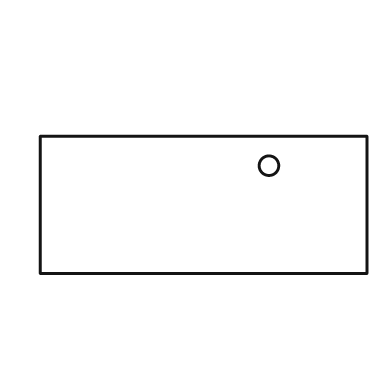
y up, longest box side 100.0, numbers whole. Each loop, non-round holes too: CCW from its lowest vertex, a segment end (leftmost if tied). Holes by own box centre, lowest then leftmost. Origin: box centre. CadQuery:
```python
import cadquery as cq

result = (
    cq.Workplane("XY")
    .moveTo(-50.0, -21.0)
    .lineTo(50.0, -21.0)
    .lineTo(50.0, 21.0)
    .lineTo(-50.0, 21.0)
    .close()
    .moveTo(20.0, 12.0)
    .circle(3.0)
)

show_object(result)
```